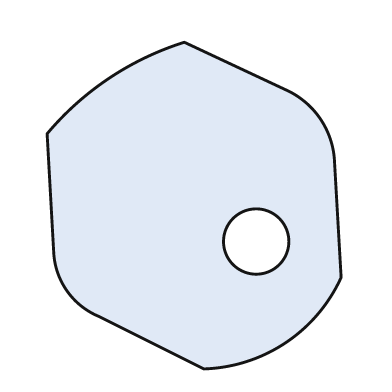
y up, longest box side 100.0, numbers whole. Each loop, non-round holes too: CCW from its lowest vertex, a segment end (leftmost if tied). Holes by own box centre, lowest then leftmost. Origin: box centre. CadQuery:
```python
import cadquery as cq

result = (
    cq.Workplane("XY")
    .moveTo(3.0, -50.0)
    .threePointArc((28.0, -42.0), (45.0, -22.0))
    .lineTo(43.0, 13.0)
    .threePointArc((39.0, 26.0), (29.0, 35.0))
    .lineTo(-3.0, 50.0)
    .threePointArc((-26.0, 39.0), (-45.0, 22.0))
    .lineTo(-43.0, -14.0)
    .threePointArc((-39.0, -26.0), (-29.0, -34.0))
    .close()
    .moveTo(19.0, -11.0)
    .circle(10.0)
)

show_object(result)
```